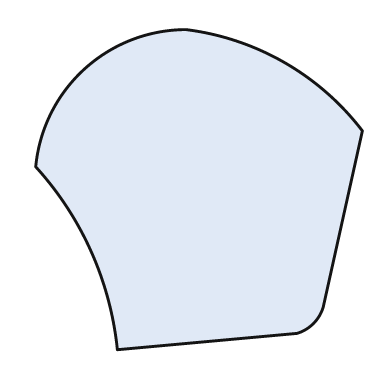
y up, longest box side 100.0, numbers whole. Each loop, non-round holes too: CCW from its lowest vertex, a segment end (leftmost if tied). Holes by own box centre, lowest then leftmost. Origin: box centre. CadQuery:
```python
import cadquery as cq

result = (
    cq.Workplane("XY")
    .moveTo(-25.0, -49.0)
    .lineTo(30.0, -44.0)
    .threePointArc((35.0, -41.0), (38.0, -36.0))
    .lineTo(50.0, 18.0)
    .threePointArc((26.0, 39.0), (-4.0, 49.0))
    .threePointArc((-35.0, 37.0), (-50.0, 7.0))
    .threePointArc((-33.0, -19.0), (-25.0, -49.0))
    .close()
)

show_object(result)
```